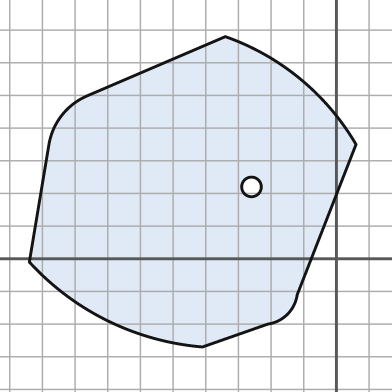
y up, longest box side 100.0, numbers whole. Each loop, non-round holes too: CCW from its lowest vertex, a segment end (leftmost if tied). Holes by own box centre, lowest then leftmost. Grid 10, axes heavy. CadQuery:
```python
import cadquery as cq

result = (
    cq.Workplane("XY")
    .moveTo(-41.0, -27.0)
    .lineTo(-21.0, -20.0)
    .threePointArc((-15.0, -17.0), (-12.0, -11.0))
    .lineTo(6.0, 35.0)
    .threePointArc((-11.0, 55.0), (-34.0, 68.0))
    .lineTo(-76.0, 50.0)
    .threePointArc((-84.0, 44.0), (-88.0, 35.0))
    .lineTo(-94.0, -1.0)
    .threePointArc((-70.0, -19.0), (-41.0, -27.0))
    .close()
    .moveTo(-26.0, 22.0)
    .circle(3.0)
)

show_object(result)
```